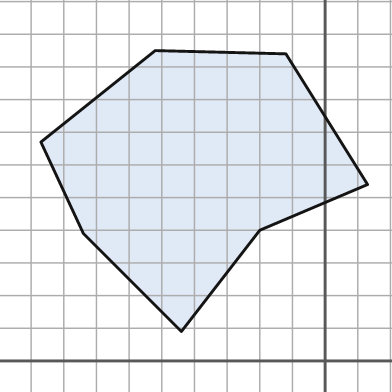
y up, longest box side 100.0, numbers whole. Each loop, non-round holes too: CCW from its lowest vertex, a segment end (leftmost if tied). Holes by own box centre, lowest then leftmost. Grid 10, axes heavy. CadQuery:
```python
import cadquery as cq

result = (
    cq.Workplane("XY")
    .moveTo(-44.0, 9.0)
    .lineTo(-20.0, 40.0)
    .lineTo(13.0, 54.0)
    .lineTo(-12.0, 94.0)
    .lineTo(-52.0, 95.0)
    .lineTo(-87.0, 67.0)
    .lineTo(-74.0, 39.0)
    .close()
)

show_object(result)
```